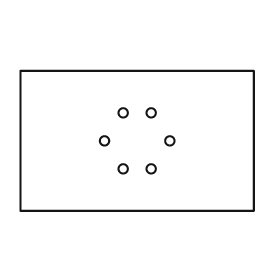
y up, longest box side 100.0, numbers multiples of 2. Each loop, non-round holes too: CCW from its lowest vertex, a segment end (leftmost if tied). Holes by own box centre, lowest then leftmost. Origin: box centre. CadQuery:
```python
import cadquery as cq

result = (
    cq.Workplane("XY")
    .moveTo(-50.0, -30.0)
    .lineTo(50.0, -30.0)
    .lineTo(50.0, 30.0)
    .lineTo(-50.0, 30.0)
    .close()
    .moveTo(-6.0, -12.0)
    .circle(2.0)
    .moveTo(6.0, -12.0)
    .circle(2.0)
    .moveTo(-14.0, 0.0)
    .circle(2.0)
    .moveTo(14.0, 0.0)
    .circle(2.0)
    .moveTo(-6.0, 12.0)
    .circle(2.0)
    .moveTo(6.0, 12.0)
    .circle(2.0)
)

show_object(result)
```